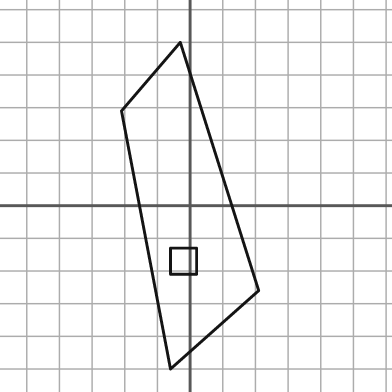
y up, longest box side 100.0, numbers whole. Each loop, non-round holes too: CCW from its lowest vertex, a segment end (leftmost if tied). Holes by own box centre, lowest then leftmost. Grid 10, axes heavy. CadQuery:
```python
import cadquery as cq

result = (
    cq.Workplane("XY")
    .moveTo(-6.0, -50.0)
    .lineTo(21.0, -26.0)
    .lineTo(-3.0, 50.0)
    .lineTo(-21.0, 29.0)
    .close()
    .moveTo(-6.0, -21.0)
    .lineTo(2.0, -21.0)
    .lineTo(2.0, -13.0)
    .lineTo(-6.0, -13.0)
    .close()
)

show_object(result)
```